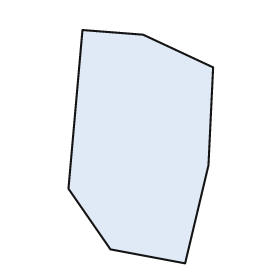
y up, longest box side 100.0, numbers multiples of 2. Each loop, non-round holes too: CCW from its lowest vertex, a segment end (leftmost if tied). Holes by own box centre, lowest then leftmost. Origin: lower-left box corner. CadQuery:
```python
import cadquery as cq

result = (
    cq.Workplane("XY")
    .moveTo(50.0, 0.0)
    .lineTo(60.0, 42.0)
    .lineTo(62.0, 84.0)
    .lineTo(32.0, 98.0)
    .lineTo(6.0, 100.0)
    .lineTo(0.0, 32.0)
    .lineTo(18.0, 6.0)
    .close()
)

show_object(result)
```